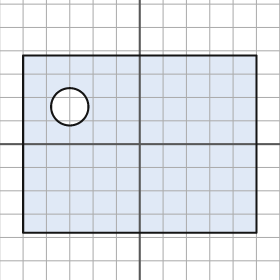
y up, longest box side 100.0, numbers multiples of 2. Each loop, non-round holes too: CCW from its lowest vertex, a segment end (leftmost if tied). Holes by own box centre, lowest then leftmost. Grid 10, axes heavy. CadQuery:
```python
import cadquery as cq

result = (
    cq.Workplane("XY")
    .moveTo(-50.0, -38.0)
    .lineTo(50.0, -38.0)
    .lineTo(50.0, 38.0)
    .lineTo(-50.0, 38.0)
    .close()
    .moveTo(-30.0, 16.0)
    .circle(8.0)
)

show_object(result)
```